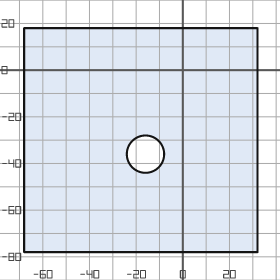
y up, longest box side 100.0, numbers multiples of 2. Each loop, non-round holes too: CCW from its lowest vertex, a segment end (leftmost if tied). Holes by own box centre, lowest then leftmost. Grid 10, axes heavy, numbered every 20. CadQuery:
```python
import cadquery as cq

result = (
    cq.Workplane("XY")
    .moveTo(-68.0, -78.0)
    .lineTo(32.0, -78.0)
    .lineTo(32.0, 18.0)
    .lineTo(-68.0, 18.0)
    .close()
    .moveTo(-16.0, -36.0)
    .circle(8.0)
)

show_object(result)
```